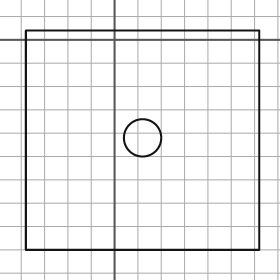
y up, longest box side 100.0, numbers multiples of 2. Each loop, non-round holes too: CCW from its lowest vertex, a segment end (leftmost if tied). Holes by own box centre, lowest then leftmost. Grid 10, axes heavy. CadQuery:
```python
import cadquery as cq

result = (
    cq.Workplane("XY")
    .moveTo(-38.0, -90.0)
    .lineTo(62.0, -90.0)
    .lineTo(62.0, 4.0)
    .lineTo(-38.0, 4.0)
    .close()
    .moveTo(12.0, -42.0)
    .circle(8.0)
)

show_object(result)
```